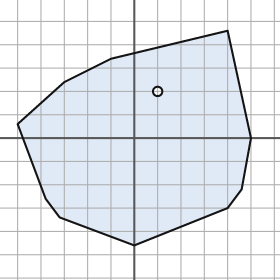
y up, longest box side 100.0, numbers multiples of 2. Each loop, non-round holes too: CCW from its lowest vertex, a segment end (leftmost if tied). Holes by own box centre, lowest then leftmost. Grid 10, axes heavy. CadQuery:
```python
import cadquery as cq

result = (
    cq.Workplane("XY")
    .moveTo(0.0, -46.0)
    .lineTo(40.0, -30.0)
    .lineTo(46.0, -22.0)
    .lineTo(50.0, 0.0)
    .lineTo(40.0, 46.0)
    .lineTo(-10.0, 34.0)
    .lineTo(-30.0, 24.0)
    .lineTo(-50.0, 6.0)
    .lineTo(-38.0, -26.0)
    .lineTo(-32.0, -34.0)
    .close()
    .moveTo(10.0, 20.0)
    .circle(2.0)
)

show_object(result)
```